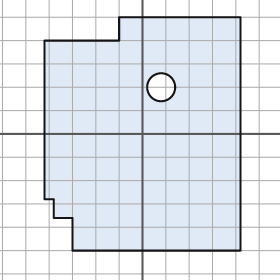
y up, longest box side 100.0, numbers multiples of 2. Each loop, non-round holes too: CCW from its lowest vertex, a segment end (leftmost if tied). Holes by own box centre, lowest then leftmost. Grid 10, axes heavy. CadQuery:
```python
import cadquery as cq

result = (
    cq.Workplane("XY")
    .moveTo(-30.0, -50.0)
    .lineTo(42.0, -50.0)
    .lineTo(42.0, 50.0)
    .lineTo(-10.0, 50.0)
    .lineTo(-10.0, 40.0)
    .lineTo(-42.0, 40.0)
    .lineTo(-42.0, -28.0)
    .lineTo(-38.0, -28.0)
    .lineTo(-38.0, -36.0)
    .lineTo(-30.0, -36.0)
    .close()
    .moveTo(8.0, 20.0)
    .circle(6.0)
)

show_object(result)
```